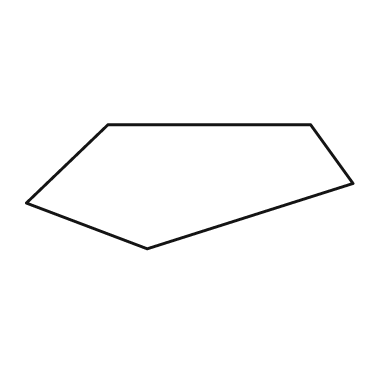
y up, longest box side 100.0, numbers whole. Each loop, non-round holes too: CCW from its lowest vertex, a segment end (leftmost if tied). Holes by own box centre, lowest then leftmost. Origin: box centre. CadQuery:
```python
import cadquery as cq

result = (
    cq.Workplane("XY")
    .moveTo(-13.0, -19.0)
    .lineTo(50.0, 1.0)
    .lineTo(37.0, 19.0)
    .lineTo(-25.0, 19.0)
    .lineTo(-50.0, -5.0)
    .close()
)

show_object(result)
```